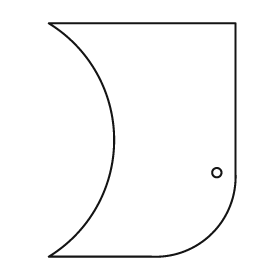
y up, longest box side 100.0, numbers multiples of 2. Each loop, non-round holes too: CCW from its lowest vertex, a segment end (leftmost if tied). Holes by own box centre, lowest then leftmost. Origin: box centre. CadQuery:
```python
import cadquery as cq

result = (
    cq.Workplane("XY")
    .moveTo(-40.0, -50.0)
    .lineTo(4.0, -50.0)
    .threePointArc((30.0, -40.0), (40.0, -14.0))
    .lineTo(40.0, 50.0)
    .lineTo(-40.0, 50.0)
    .threePointArc((-12.0, 0.0), (-40.0, -50.0))
    .close()
    .moveTo(32.0, -14.0)
    .circle(2.0)
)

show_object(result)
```